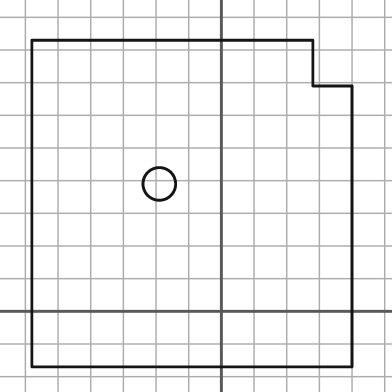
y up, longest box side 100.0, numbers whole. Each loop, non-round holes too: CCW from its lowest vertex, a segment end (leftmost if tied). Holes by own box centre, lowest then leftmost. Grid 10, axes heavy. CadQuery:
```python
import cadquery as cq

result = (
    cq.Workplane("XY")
    .moveTo(-58.0, -17.0)
    .lineTo(40.0, -17.0)
    .lineTo(40.0, 69.0)
    .lineTo(28.0, 69.0)
    .lineTo(28.0, 83.0)
    .lineTo(-58.0, 83.0)
    .close()
    .moveTo(-19.0, 39.0)
    .circle(5.0)
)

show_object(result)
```